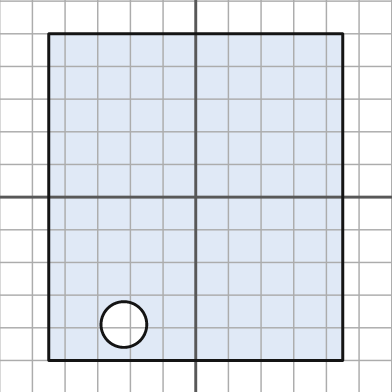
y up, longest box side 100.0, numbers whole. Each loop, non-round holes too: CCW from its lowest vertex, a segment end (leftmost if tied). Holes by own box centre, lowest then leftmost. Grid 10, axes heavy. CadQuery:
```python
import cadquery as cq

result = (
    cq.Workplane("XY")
    .moveTo(-45.0, -50.0)
    .lineTo(45.0, -50.0)
    .lineTo(45.0, 50.0)
    .lineTo(-45.0, 50.0)
    .close()
    .moveTo(-22.0, -39.0)
    .circle(7.0)
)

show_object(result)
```